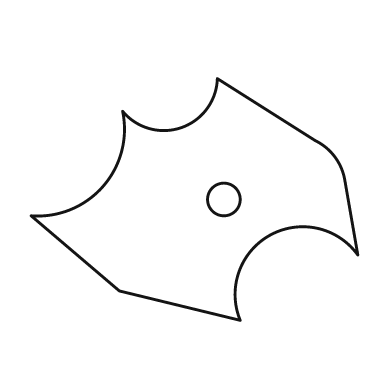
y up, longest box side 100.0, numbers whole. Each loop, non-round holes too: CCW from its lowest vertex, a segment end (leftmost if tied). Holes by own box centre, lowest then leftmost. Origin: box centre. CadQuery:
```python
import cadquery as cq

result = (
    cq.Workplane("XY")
    .moveTo(14.0, -37.0)
    .threePointArc((23.0, -11.0), (50.0, -17.0))
    .lineTo(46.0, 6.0)
    .threePointArc((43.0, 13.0), (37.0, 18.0))
    .lineTo(7.0, 37.0)
    .threePointArc((-4.0, 22.0), (-22.0, 27.0))
    .threePointArc((-28.0, 4.0), (-50.0, -5.0))
    .lineTo(-23.0, -28.0)
    .close()
    .moveTo(9.0, 0.0)
    .circle(5.0)
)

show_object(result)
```